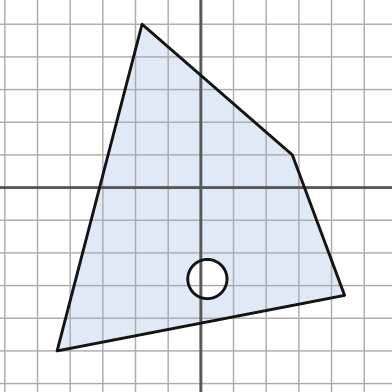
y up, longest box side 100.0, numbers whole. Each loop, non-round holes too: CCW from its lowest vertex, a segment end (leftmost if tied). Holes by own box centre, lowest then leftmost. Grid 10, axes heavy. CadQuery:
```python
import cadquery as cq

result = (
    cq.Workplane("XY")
    .moveTo(-44.0, -50.0)
    .lineTo(44.0, -33.0)
    .lineTo(28.0, 10.0)
    .lineTo(-18.0, 50.0)
    .close()
    .moveTo(2.0, -28.0)
    .circle(6.0)
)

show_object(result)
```